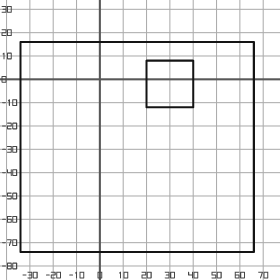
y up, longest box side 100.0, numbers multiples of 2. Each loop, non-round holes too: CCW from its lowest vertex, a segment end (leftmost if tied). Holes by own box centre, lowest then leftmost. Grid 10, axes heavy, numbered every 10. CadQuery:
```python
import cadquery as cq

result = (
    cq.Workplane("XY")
    .moveTo(-34.0, -74.0)
    .lineTo(66.0, -74.0)
    .lineTo(66.0, 16.0)
    .lineTo(-34.0, 16.0)
    .close()
    .moveTo(20.0, -12.0)
    .lineTo(40.0, -12.0)
    .lineTo(40.0, 8.0)
    .lineTo(20.0, 8.0)
    .close()
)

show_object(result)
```